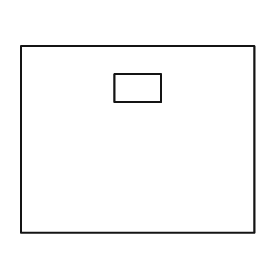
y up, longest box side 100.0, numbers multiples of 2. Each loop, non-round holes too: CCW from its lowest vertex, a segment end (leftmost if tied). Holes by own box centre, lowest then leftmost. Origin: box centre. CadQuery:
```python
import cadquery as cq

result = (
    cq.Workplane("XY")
    .moveTo(-50.0, -40.0)
    .lineTo(50.0, -40.0)
    .lineTo(50.0, 40.0)
    .lineTo(-50.0, 40.0)
    .close()
    .moveTo(-10.0, 16.0)
    .lineTo(10.0, 16.0)
    .lineTo(10.0, 28.0)
    .lineTo(-10.0, 28.0)
    .close()
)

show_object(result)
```